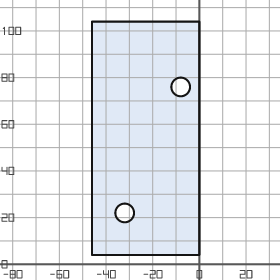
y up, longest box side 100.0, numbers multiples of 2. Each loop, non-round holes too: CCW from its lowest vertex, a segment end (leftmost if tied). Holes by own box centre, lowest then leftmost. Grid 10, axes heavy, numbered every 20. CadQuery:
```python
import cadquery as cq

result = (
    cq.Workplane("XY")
    .moveTo(-46.0, 4.0)
    .lineTo(0.0, 4.0)
    .lineTo(0.0, 104.0)
    .lineTo(-46.0, 104.0)
    .close()
    .moveTo(-32.0, 22.0)
    .circle(4.0)
    .moveTo(-8.0, 76.0)
    .circle(4.0)
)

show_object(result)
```